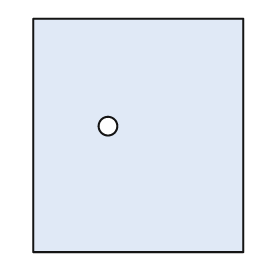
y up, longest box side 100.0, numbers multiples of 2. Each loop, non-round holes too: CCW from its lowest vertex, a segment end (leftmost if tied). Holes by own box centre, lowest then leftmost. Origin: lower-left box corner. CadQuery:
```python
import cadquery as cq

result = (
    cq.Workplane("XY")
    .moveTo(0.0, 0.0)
    .lineTo(90.0, 0.0)
    .lineTo(90.0, 100.0)
    .lineTo(0.0, 100.0)
    .close()
    .moveTo(32.0, 54.0)
    .circle(4.0)
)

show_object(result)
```